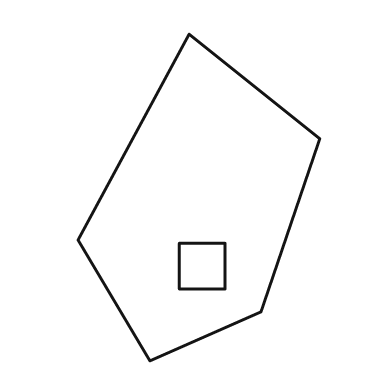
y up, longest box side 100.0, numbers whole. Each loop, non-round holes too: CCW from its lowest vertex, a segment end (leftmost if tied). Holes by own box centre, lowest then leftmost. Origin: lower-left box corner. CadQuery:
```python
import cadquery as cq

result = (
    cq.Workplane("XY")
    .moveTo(22.0, 0.0)
    .lineTo(56.0, 15.0)
    .lineTo(74.0, 68.0)
    .lineTo(34.0, 100.0)
    .lineTo(0.0, 37.0)
    .close()
    .moveTo(31.0, 22.0)
    .lineTo(45.0, 22.0)
    .lineTo(45.0, 36.0)
    .lineTo(31.0, 36.0)
    .close()
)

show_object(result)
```